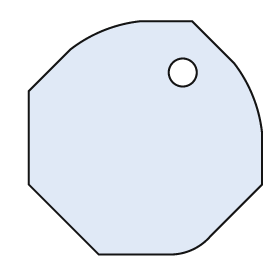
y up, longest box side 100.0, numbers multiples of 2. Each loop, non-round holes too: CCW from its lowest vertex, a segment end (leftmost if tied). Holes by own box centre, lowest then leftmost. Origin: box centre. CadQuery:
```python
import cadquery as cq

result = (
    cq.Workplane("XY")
    .moveTo(-20.0, -50.0)
    .lineTo(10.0, -50.0)
    .threePointArc((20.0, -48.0), (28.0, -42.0))
    .lineTo(50.0, -20.0)
    .lineTo(50.0, 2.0)
    .threePointArc((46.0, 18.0), (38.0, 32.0))
    .lineTo(20.0, 50.0)
    .lineTo(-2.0, 50.0)
    .threePointArc((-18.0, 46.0), (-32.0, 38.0))
    .lineTo(-50.0, 20.0)
    .lineTo(-50.0, -20.0)
    .close()
    .moveTo(16.0, 28.0)
    .circle(6.0)
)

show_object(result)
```